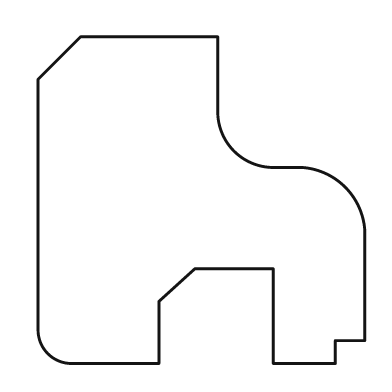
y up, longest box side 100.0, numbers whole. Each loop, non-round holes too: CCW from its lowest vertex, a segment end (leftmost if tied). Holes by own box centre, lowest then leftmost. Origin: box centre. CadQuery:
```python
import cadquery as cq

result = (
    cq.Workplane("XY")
    .moveTo(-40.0, -50.0)
    .lineTo(-13.0, -50.0)
    .lineTo(-13.0, -31.0)
    .lineTo(-2.0, -21.0)
    .lineTo(22.0, -21.0)
    .lineTo(22.0, -50.0)
    .lineTo(41.0, -50.0)
    .lineTo(41.0, -43.0)
    .lineTo(50.0, -43.0)
    .lineTo(50.0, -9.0)
    .threePointArc((44.0, 4.0), (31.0, 10.0))
    .lineTo(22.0, 10.0)
    .threePointArc((10.0, 15.0), (5.0, 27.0))
    .lineTo(5.0, 50.0)
    .lineTo(-37.0, 50.0)
    .lineTo(-50.0, 37.0)
    .lineTo(-50.0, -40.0)
    .threePointArc((-47.0, -47.0), (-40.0, -50.0))
    .close()
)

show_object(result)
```